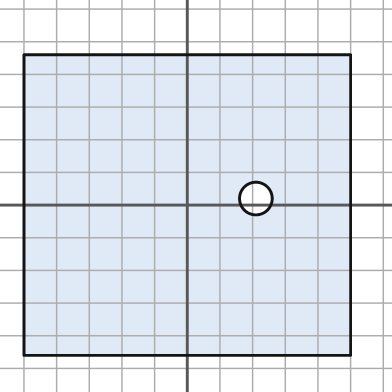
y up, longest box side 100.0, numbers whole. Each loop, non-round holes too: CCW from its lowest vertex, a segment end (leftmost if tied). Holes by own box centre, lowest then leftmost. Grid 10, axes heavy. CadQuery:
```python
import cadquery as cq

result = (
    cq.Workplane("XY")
    .moveTo(-50.0, -46.0)
    .lineTo(50.0, -46.0)
    .lineTo(50.0, 46.0)
    .lineTo(-50.0, 46.0)
    .close()
    .moveTo(21.0, 2.0)
    .circle(5.0)
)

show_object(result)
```